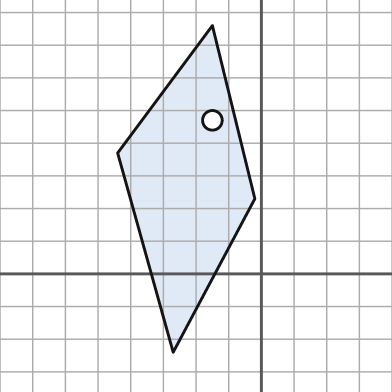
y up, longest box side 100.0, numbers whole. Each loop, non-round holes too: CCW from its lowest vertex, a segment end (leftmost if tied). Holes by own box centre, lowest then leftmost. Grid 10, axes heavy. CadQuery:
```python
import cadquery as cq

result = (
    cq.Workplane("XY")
    .moveTo(-27.0, -24.0)
    .lineTo(-2.0, 23.0)
    .lineTo(-15.0, 76.0)
    .lineTo(-44.0, 37.0)
    .close()
    .moveTo(-15.0, 47.0)
    .circle(3.0)
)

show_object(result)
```